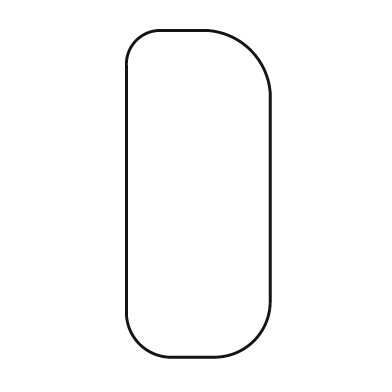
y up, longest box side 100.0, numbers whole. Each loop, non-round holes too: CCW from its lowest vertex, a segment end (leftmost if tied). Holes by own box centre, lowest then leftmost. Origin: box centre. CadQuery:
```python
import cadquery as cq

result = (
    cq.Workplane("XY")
    .moveTo(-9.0, -50.0)
    .lineTo(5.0, -50.0)
    .threePointArc((17.0, -45.0), (22.0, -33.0))
    .lineTo(22.0, 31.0)
    .threePointArc((16.0, 44.0), (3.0, 50.0))
    .lineTo(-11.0, 50.0)
    .threePointArc((-19.0, 47.0), (-22.0, 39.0))
    .lineTo(-22.0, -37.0)
    .threePointArc((-18.0, -46.0), (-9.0, -50.0))
    .close()
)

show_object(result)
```